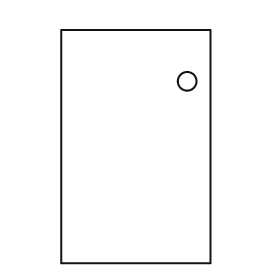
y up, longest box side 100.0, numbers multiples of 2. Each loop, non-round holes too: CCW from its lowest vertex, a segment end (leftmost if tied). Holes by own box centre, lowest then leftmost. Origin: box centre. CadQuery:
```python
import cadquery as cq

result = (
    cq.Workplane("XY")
    .moveTo(-32.0, -50.0)
    .lineTo(32.0, -50.0)
    .lineTo(32.0, 50.0)
    .lineTo(-32.0, 50.0)
    .close()
    .moveTo(22.0, 28.0)
    .circle(4.0)
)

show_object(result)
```